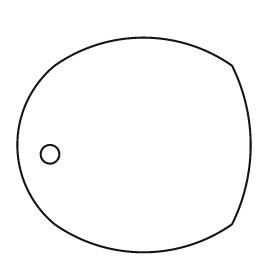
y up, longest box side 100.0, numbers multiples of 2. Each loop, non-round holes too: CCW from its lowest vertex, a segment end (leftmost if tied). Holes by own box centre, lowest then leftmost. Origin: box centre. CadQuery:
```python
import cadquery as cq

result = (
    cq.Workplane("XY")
    .moveTo(-34.0, -34.0)
    .threePointArc((4.0, -46.0), (42.0, -34.0))
    .threePointArc((50.0, 0.0), (42.0, 34.0))
    .threePointArc((4.0, 46.0), (-34.0, 34.0))
    .threePointArc((-50.0, 0.0), (-34.0, -34.0))
    .close()
    .moveTo(-36.0, -4.0)
    .circle(4.0)
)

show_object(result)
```